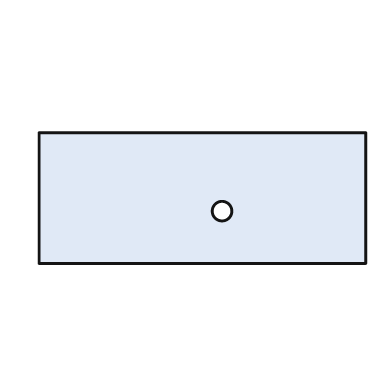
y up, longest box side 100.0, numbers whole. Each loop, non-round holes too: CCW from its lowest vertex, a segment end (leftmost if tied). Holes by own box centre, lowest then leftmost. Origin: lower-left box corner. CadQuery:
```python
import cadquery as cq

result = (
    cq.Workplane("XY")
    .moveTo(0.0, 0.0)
    .lineTo(100.0, 0.0)
    .lineTo(100.0, 40.0)
    .lineTo(0.0, 40.0)
    .close()
    .moveTo(56.0, 16.0)
    .circle(3.0)
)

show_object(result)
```